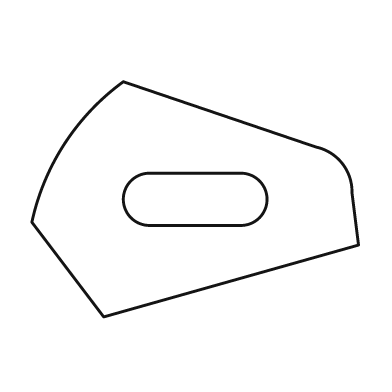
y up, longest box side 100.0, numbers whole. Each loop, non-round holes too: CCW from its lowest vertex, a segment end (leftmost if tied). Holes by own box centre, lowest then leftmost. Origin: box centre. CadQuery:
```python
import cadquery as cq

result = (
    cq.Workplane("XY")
    .moveTo(-28.0, -36.0)
    .lineTo(50.0, -14.0)
    .lineTo(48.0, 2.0)
    .threePointArc((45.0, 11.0), (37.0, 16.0))
    .lineTo(-22.0, 36.0)
    .threePointArc((-40.0, 17.0), (-50.0, -7.0))
    .close()
    .moveTo(-14.0, -8.0)
    .lineTo(14.0, -8.0)
    .threePointArc((22.0, 0.0), (14.0, 8.0))
    .lineTo(-14.0, 8.0)
    .threePointArc((-22.0, 0.0), (-14.0, -8.0))
    .close()
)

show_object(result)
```